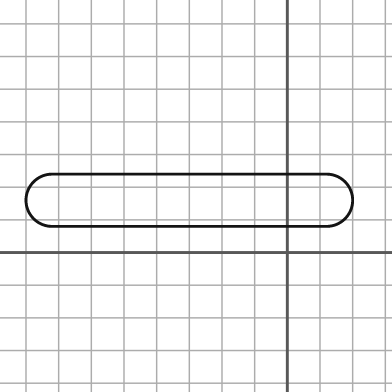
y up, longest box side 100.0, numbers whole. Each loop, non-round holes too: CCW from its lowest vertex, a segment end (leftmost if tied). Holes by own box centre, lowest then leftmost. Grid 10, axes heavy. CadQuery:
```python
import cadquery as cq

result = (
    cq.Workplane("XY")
    .moveTo(-72.0, 8.0)
    .lineTo(12.0, 8.0)
    .threePointArc((20.0, 16.0), (12.0, 24.0))
    .lineTo(-72.0, 24.0)
    .threePointArc((-80.0, 16.0), (-72.0, 8.0))
    .close()
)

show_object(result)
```